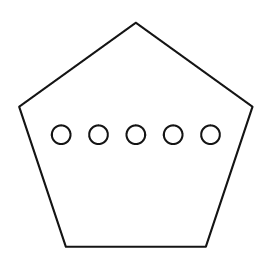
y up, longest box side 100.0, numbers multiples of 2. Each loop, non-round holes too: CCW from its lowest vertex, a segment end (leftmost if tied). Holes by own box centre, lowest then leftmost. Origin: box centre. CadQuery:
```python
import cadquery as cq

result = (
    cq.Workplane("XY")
    .moveTo(-30.0, -48.0)
    .lineTo(30.0, -48.0)
    .lineTo(50.0, 12.0)
    .lineTo(0.0, 48.0)
    .lineTo(-50.0, 12.0)
    .close()
    .moveTo(-32.0, 0.0)
    .circle(4.0)
    .moveTo(-16.0, 0.0)
    .circle(4.0)
    .moveTo(0.0, 0.0)
    .circle(4.0)
    .moveTo(16.0, 0.0)
    .circle(4.0)
    .moveTo(32.0, 0.0)
    .circle(4.0)
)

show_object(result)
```